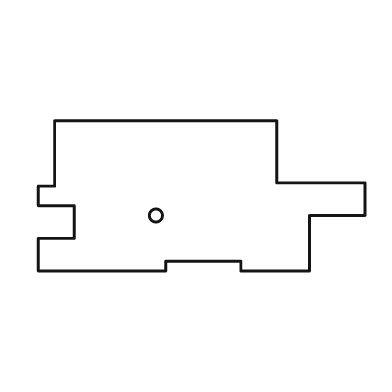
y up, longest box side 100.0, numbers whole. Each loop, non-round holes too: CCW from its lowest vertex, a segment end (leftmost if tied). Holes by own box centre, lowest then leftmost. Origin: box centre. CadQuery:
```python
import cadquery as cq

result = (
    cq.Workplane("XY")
    .moveTo(-50.0, -23.0)
    .lineTo(-11.0, -23.0)
    .lineTo(-11.0, -20.0)
    .lineTo(12.0, -20.0)
    .lineTo(12.0, -23.0)
    .lineTo(33.0, -23.0)
    .lineTo(33.0, -6.0)
    .lineTo(50.0, -6.0)
    .lineTo(50.0, 4.0)
    .lineTo(23.0, 4.0)
    .lineTo(23.0, 23.0)
    .lineTo(-45.0, 23.0)
    .lineTo(-45.0, 3.0)
    .lineTo(-50.0, 3.0)
    .lineTo(-50.0, -3.0)
    .lineTo(-39.0, -3.0)
    .lineTo(-39.0, -13.0)
    .lineTo(-50.0, -13.0)
    .close()
    .moveTo(-14.0, -6.0)
    .circle(2.0)
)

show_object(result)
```